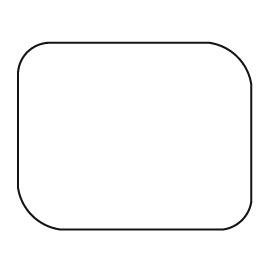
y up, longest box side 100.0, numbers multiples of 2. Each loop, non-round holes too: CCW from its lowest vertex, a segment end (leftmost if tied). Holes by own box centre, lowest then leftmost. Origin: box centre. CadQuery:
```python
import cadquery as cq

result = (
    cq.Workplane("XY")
    .moveTo(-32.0, -40.0)
    .lineTo(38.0, -40.0)
    .threePointArc((46.0, -36.0), (50.0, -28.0))
    .lineTo(50.0, 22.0)
    .threePointArc((44.0, 34.0), (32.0, 40.0))
    .lineTo(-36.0, 40.0)
    .threePointArc((-46.0, 36.0), (-50.0, 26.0))
    .lineTo(-50.0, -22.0)
    .threePointArc((-44.0, -34.0), (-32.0, -40.0))
    .close()
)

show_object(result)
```